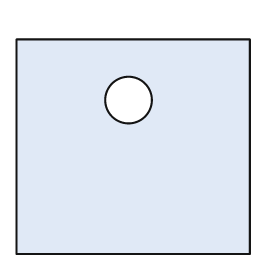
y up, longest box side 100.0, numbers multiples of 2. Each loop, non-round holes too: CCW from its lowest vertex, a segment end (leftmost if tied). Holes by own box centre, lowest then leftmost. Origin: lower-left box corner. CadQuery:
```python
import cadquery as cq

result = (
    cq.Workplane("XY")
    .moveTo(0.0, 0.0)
    .lineTo(100.0, 0.0)
    .lineTo(100.0, 92.0)
    .lineTo(0.0, 92.0)
    .close()
    .moveTo(48.0, 66.0)
    .circle(10.0)
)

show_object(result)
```